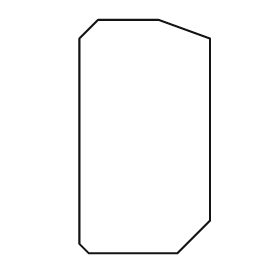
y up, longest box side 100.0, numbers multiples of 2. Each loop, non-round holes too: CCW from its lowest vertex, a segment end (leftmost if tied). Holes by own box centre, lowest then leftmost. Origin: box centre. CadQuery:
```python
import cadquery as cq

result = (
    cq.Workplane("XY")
    .moveTo(-24.0, -50.0)
    .lineTo(14.0, -50.0)
    .lineTo(28.0, -36.0)
    .lineTo(28.0, 42.0)
    .lineTo(6.0, 50.0)
    .lineTo(-20.0, 50.0)
    .lineTo(-28.0, 42.0)
    .lineTo(-28.0, -46.0)
    .close()
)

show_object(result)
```